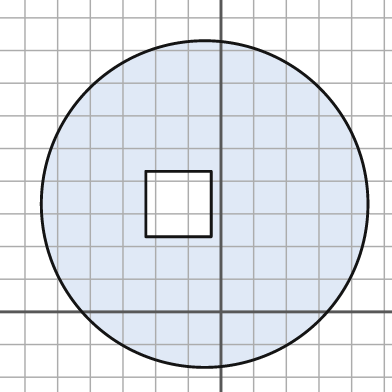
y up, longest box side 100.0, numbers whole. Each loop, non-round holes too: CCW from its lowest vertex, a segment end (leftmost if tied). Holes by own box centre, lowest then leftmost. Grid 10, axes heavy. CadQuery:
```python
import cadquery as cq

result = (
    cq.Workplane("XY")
    .moveTo(-5.0, 33.0)
    .circle(50.0)
    .moveTo(-23.0, 23.0)
    .lineTo(-3.0, 23.0)
    .lineTo(-3.0, 43.0)
    .lineTo(-23.0, 43.0)
    .close()
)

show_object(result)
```